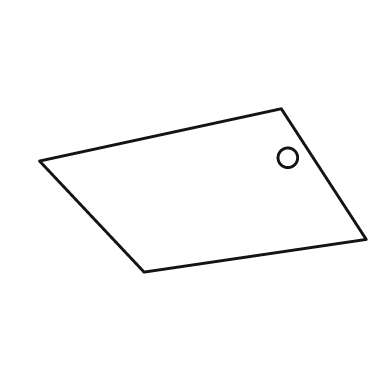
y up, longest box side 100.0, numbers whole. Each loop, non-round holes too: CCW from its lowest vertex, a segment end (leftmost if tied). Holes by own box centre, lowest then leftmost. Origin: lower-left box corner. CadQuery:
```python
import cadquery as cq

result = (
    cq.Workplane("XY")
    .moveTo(32.0, 0.0)
    .lineTo(100.0, 10.0)
    .lineTo(74.0, 50.0)
    .lineTo(0.0, 34.0)
    .close()
    .moveTo(76.0, 35.0)
    .circle(3.0)
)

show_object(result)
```